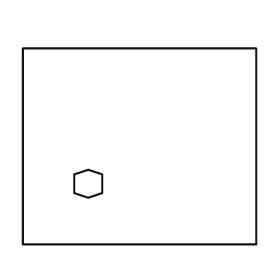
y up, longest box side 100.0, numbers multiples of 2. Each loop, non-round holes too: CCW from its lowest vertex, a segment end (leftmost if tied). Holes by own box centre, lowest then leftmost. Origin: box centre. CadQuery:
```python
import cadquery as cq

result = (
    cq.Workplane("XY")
    .moveTo(-50.0, -42.0)
    .lineTo(50.0, -42.0)
    .lineTo(50.0, 42.0)
    .lineTo(-50.0, 42.0)
    .close()
    .moveTo(-22.0, -22.0)
    .lineTo(-16.0, -20.0)
    .lineTo(-16.0, -12.0)
    .lineTo(-22.0, -10.0)
    .lineTo(-28.0, -12.0)
    .lineTo(-28.0, -20.0)
    .close()
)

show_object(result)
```